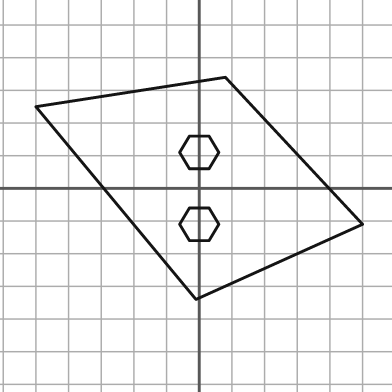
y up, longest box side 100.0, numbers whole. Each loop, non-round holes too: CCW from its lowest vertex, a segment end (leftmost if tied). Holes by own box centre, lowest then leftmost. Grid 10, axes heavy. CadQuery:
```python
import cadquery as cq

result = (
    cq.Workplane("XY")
    .moveTo(-1.0, -34.0)
    .lineTo(50.0, -11.0)
    .lineTo(8.0, 34.0)
    .lineTo(-50.0, 25.0)
    .close()
    .moveTo(-3.0, -16.0)
    .lineTo(3.0, -16.0)
    .lineTo(6.0, -11.0)
    .lineTo(3.0, -6.0)
    .lineTo(-3.0, -6.0)
    .lineTo(-6.0, -11.0)
    .close()
    .moveTo(-3.0, 6.0)
    .lineTo(3.0, 6.0)
    .lineTo(6.0, 11.0)
    .lineTo(3.0, 16.0)
    .lineTo(-3.0, 16.0)
    .lineTo(-6.0, 11.0)
    .close()
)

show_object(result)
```